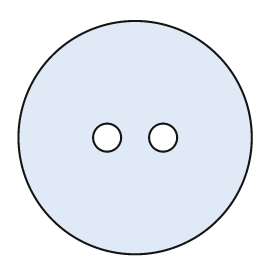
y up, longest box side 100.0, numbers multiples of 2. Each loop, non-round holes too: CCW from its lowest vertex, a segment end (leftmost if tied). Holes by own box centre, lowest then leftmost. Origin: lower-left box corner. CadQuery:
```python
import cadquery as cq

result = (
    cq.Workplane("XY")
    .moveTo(50.0, 50.0)
    .circle(50.0)
    .moveTo(38.0, 50.0)
    .circle(6.0)
    .moveTo(62.0, 50.0)
    .circle(6.0)
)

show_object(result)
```